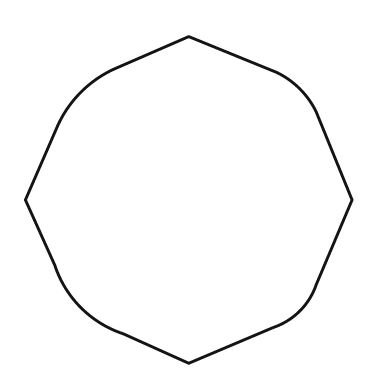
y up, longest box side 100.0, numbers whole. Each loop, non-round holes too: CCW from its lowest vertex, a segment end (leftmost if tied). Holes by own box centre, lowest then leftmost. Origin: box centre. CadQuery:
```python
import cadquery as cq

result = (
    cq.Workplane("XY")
    .moveTo(0.0, -50.0)
    .lineTo(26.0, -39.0)
    .threePointArc((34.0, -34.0), (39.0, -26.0))
    .lineTo(50.0, 0.0)
    .lineTo(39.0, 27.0)
    .threePointArc((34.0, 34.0), (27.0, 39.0))
    .lineTo(0.0, 50.0)
    .lineTo(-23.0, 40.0)
    .threePointArc((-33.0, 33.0), (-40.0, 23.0))
    .lineTo(-50.0, 0.0)
    .lineTo(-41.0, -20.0)
    .threePointArc((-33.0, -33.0), (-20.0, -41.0))
    .close()
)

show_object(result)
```